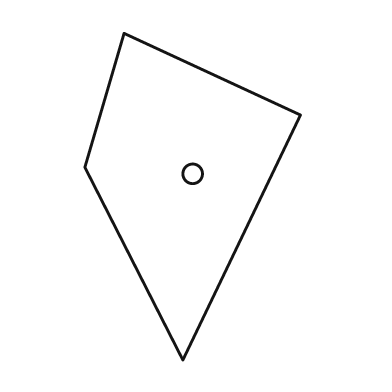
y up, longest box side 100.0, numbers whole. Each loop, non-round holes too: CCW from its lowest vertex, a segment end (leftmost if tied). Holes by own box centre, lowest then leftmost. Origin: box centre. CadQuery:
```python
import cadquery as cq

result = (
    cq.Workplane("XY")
    .moveTo(-3.0, -50.0)
    .lineTo(33.0, 25.0)
    .lineTo(-21.0, 50.0)
    .lineTo(-33.0, 9.0)
    .close()
    .moveTo(0.0, 7.0)
    .circle(3.0)
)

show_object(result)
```